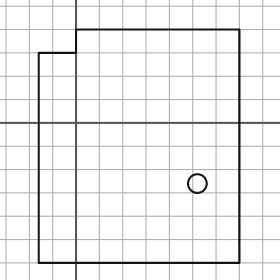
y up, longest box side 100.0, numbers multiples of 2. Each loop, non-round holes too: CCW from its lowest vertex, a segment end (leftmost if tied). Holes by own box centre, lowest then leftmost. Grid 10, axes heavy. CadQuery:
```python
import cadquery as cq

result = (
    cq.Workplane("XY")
    .moveTo(-16.0, -60.0)
    .lineTo(70.0, -60.0)
    .lineTo(70.0, 40.0)
    .lineTo(0.0, 40.0)
    .lineTo(0.0, 30.0)
    .lineTo(-16.0, 30.0)
    .close()
    .moveTo(52.0, -26.0)
    .circle(4.0)
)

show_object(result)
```